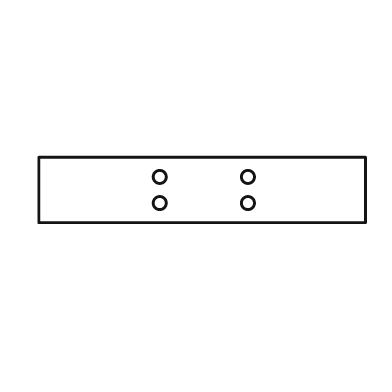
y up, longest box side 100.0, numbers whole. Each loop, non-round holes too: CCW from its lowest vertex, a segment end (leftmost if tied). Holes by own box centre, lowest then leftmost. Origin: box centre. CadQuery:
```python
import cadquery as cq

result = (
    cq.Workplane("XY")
    .moveTo(-50.0, -10.0)
    .lineTo(50.0, -10.0)
    .lineTo(50.0, 10.0)
    .lineTo(-50.0, 10.0)
    .close()
    .moveTo(-13.0, -4.0)
    .circle(2.0)
    .moveTo(14.0, -4.0)
    .circle(2.0)
    .moveTo(-13.0, 4.0)
    .circle(2.0)
    .moveTo(14.0, 4.0)
    .circle(2.0)
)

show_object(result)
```